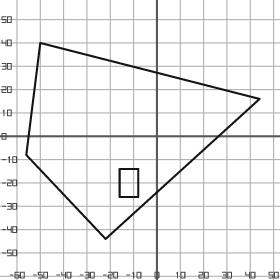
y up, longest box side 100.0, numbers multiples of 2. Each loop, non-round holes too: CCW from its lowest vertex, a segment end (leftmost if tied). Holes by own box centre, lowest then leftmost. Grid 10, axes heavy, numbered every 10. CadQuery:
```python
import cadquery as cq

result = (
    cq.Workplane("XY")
    .moveTo(-22.0, -44.0)
    .lineTo(44.0, 16.0)
    .lineTo(-50.0, 40.0)
    .lineTo(-56.0, -8.0)
    .close()
    .moveTo(-16.0, -26.0)
    .lineTo(-8.0, -26.0)
    .lineTo(-8.0, -14.0)
    .lineTo(-16.0, -14.0)
    .close()
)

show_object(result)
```